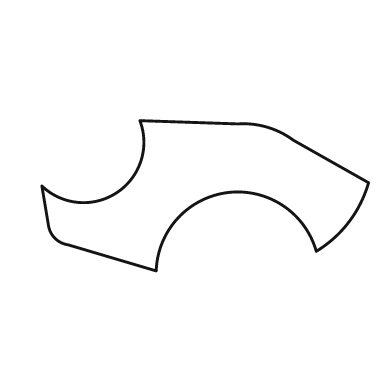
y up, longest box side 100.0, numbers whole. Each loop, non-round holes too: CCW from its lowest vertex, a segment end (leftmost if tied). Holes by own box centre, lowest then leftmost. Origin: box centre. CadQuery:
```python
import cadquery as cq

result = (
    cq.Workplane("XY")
    .moveTo(-15.0, -23.0)
    .threePointArc((7.0, 1.0), (34.0, -17.0))
    .threePointArc((44.0, -8.0), (50.0, 4.0))
    .lineTo(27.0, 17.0)
    .threePointArc((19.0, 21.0), (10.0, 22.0))
    .lineTo(-20.0, 23.0)
    .threePointArc((-27.0, 1.0), (-50.0, 3.0))
    .lineTo(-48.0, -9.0)
    .threePointArc((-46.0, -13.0), (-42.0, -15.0))
    .close()
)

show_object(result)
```